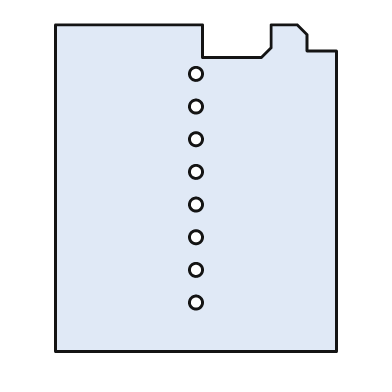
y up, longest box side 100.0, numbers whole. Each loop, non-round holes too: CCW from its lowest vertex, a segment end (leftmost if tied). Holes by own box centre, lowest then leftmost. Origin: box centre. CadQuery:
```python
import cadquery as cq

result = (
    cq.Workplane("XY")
    .moveTo(-43.0, -50.0)
    .lineTo(43.0, -50.0)
    .lineTo(43.0, 42.0)
    .lineTo(34.0, 42.0)
    .lineTo(34.0, 47.0)
    .lineTo(31.0, 50.0)
    .lineTo(23.0, 50.0)
    .lineTo(23.0, 43.0)
    .lineTo(20.0, 40.0)
    .lineTo(2.0, 40.0)
    .lineTo(2.0, 50.0)
    .lineTo(-43.0, 50.0)
    .close()
    .moveTo(0.0, -35.0)
    .circle(2.0)
    .moveTo(0.0, -25.0)
    .circle(2.0)
    .moveTo(0.0, -15.0)
    .circle(2.0)
    .moveTo(0.0, -5.0)
    .circle(2.0)
    .moveTo(0.0, 5.0)
    .circle(2.0)
    .moveTo(0.0, 15.0)
    .circle(2.0)
    .moveTo(0.0, 25.0)
    .circle(2.0)
    .moveTo(0.0, 35.0)
    .circle(2.0)
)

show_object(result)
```